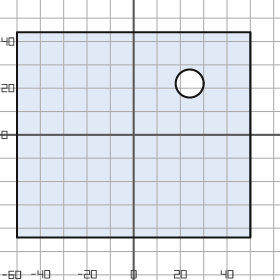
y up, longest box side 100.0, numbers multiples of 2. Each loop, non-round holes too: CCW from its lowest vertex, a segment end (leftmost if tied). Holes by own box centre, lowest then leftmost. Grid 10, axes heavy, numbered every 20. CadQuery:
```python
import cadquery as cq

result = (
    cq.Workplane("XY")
    .moveTo(-50.0, -44.0)
    .lineTo(50.0, -44.0)
    .lineTo(50.0, 44.0)
    .lineTo(-50.0, 44.0)
    .close()
    .moveTo(24.0, 22.0)
    .circle(6.0)
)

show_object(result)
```